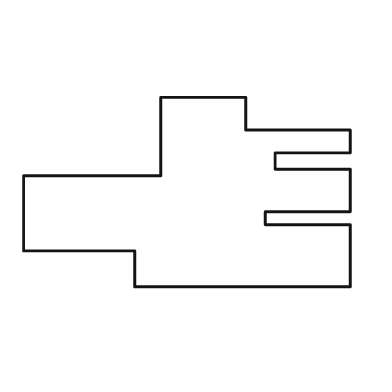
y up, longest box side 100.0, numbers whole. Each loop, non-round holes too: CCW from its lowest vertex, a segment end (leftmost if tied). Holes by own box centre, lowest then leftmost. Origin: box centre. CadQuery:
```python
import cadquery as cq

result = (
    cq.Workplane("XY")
    .moveTo(-16.0, -29.0)
    .lineTo(50.0, -29.0)
    .lineTo(50.0, -10.0)
    .lineTo(24.0, -10.0)
    .lineTo(24.0, -6.0)
    .lineTo(50.0, -6.0)
    .lineTo(50.0, 7.0)
    .lineTo(27.0, 7.0)
    .lineTo(27.0, 12.0)
    .lineTo(50.0, 12.0)
    .lineTo(50.0, 19.0)
    .lineTo(18.0, 19.0)
    .lineTo(18.0, 29.0)
    .lineTo(-8.0, 29.0)
    .lineTo(-8.0, 5.0)
    .lineTo(-50.0, 5.0)
    .lineTo(-50.0, -18.0)
    .lineTo(-16.0, -18.0)
    .close()
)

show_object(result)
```